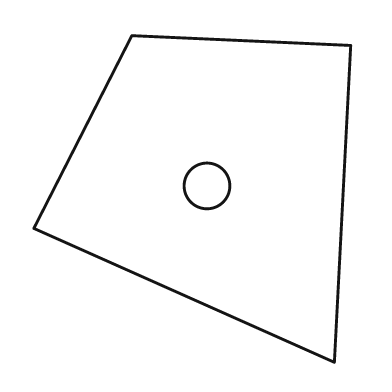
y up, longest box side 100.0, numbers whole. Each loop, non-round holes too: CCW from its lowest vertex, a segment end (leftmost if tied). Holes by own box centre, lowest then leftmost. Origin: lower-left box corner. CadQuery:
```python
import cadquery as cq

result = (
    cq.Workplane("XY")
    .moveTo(92.0, 0.0)
    .lineTo(97.0, 97.0)
    .lineTo(30.0, 100.0)
    .lineTo(0.0, 41.0)
    .close()
    .moveTo(53.0, 54.0)
    .circle(7.0)
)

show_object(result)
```